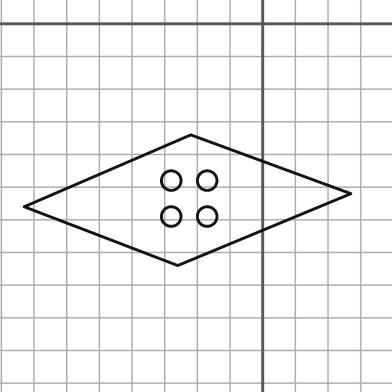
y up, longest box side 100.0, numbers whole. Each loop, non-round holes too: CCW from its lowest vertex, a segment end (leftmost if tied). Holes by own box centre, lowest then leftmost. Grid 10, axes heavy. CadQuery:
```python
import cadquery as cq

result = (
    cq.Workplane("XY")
    .moveTo(-26.0, -74.0)
    .lineTo(27.0, -52.0)
    .lineTo(-22.0, -34.0)
    .lineTo(-73.0, -56.0)
    .close()
    .moveTo(-28.0, -59.0)
    .circle(3.0)
    .moveTo(-17.0, -59.0)
    .circle(3.0)
    .moveTo(-28.0, -48.0)
    .circle(3.0)
    .moveTo(-17.0, -48.0)
    .circle(3.0)
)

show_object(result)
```